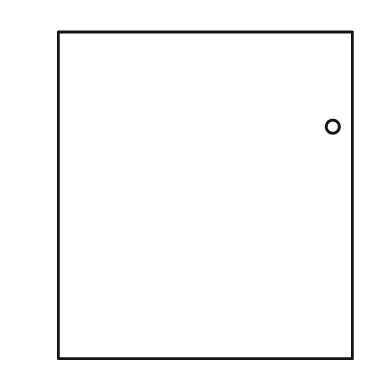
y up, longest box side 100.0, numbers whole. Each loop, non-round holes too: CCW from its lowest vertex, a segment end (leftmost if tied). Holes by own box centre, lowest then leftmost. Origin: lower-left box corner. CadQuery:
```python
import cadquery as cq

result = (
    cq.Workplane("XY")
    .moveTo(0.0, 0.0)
    .lineTo(90.0, 0.0)
    .lineTo(90.0, 100.0)
    .lineTo(0.0, 100.0)
    .close()
    .moveTo(84.0, 71.0)
    .circle(2.0)
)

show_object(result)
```